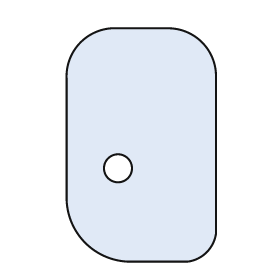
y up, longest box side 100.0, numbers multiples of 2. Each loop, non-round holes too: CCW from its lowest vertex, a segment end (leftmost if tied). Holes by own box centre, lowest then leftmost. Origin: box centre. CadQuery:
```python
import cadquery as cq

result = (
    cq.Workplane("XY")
    .moveTo(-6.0, -50.0)
    .lineTo(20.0, -50.0)
    .threePointArc((28.0, -46.0), (32.0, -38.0))
    .lineTo(32.0, 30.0)
    .threePointArc((26.0, 44.0), (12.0, 50.0))
    .lineTo(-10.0, 50.0)
    .threePointArc((-26.0, 44.0), (-32.0, 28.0))
    .lineTo(-32.0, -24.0)
    .threePointArc((-24.0, -42.0), (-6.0, -50.0))
    .close()
    .moveTo(-10.0, -10.0)
    .circle(6.0)
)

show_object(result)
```